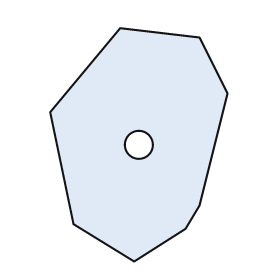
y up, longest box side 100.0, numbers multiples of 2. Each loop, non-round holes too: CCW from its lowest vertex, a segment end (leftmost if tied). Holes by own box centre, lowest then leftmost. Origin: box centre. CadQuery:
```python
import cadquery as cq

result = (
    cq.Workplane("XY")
    .moveTo(-2.0, -50.0)
    .lineTo(20.0, -36.0)
    .lineTo(26.0, -26.0)
    .lineTo(38.0, 22.0)
    .lineTo(26.0, 46.0)
    .lineTo(-8.0, 50.0)
    .lineTo(-38.0, 14.0)
    .lineTo(-28.0, -34.0)
    .close()
    .moveTo(0.0, 0.0)
    .circle(6.0)
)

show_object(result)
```